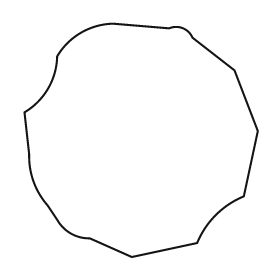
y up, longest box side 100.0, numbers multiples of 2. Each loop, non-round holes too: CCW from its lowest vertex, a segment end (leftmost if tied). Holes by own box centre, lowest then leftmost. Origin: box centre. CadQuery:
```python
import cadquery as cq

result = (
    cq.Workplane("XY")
    .moveTo(-4.0, -50.0)
    .lineTo(24.0, -44.0)
    .threePointArc((32.0, -32.0), (44.0, -24.0))
    .lineTo(50.0, 4.0)
    .lineTo(40.0, 30.0)
    .lineTo(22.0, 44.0)
    .threePointArc((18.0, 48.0), (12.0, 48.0))
    .lineTo(-12.0, 50.0)
    .threePointArc((-26.0, 46.0), (-36.0, 36.0))
    .threePointArc((-40.0, 22.0), (-50.0, 12.0))
    .lineTo(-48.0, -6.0)
    .threePointArc((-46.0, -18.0), (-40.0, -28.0))
    .lineTo(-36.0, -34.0)
    .threePointArc((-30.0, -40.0), (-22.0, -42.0))
    .close()
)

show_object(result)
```